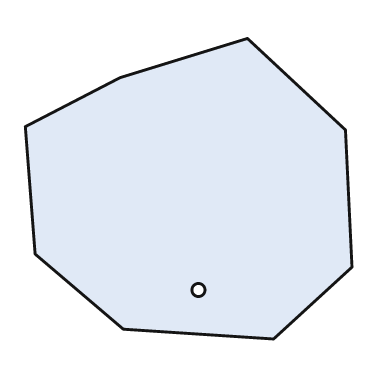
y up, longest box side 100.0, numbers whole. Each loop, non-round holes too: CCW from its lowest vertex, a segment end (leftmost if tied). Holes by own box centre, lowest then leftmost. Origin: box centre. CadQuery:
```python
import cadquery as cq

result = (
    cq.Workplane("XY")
    .moveTo(26.0, -46.0)
    .lineTo(50.0, -24.0)
    .lineTo(48.0, 18.0)
    .lineTo(18.0, 46.0)
    .lineTo(-21.0, 34.0)
    .lineTo(-50.0, 19.0)
    .lineTo(-47.0, -20.0)
    .lineTo(-20.0, -43.0)
    .close()
    .moveTo(3.0, -31.0)
    .circle(2.0)
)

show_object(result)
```